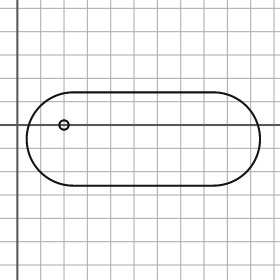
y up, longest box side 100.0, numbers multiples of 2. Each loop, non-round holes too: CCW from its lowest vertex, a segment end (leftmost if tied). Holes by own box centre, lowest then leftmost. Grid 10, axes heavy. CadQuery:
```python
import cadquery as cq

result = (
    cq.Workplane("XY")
    .moveTo(24.0, -26.0)
    .lineTo(84.0, -26.0)
    .threePointArc((104.0, -6.0), (84.0, 14.0))
    .lineTo(24.0, 14.0)
    .threePointArc((4.0, -6.0), (24.0, -26.0))
    .close()
    .moveTo(20.0, 0.0)
    .circle(2.0)
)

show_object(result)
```